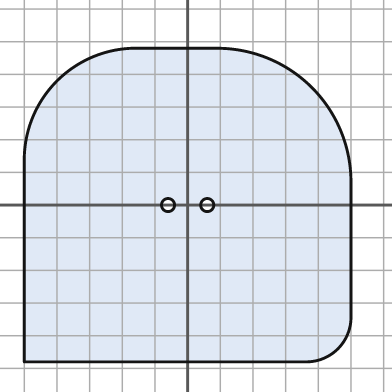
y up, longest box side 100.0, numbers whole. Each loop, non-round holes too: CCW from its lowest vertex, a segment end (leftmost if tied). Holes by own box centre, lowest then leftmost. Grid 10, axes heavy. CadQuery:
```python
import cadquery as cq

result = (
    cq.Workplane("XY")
    .moveTo(-50.0, -48.0)
    .lineTo(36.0, -48.0)
    .threePointArc((46.0, -44.0), (50.0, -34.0))
    .lineTo(50.0, 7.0)
    .threePointArc((38.0, 36.0), (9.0, 48.0))
    .lineTo(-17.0, 48.0)
    .threePointArc((-40.0, 38.0), (-50.0, 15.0))
    .close()
    .moveTo(-6.0, 0.0)
    .circle(2.0)
    .moveTo(6.0, 0.0)
    .circle(2.0)
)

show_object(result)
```